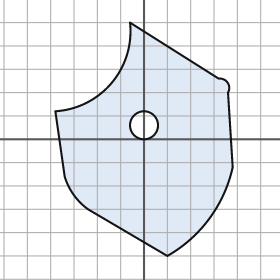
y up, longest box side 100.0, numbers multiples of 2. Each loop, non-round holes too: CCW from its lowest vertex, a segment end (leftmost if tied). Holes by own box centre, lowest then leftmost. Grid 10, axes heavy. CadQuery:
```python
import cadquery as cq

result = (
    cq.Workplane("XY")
    .moveTo(10.0, -50.0)
    .threePointArc((28.0, -34.0), (38.0, -12.0))
    .lineTo(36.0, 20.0)
    .threePointArc((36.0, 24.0), (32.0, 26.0))
    .lineTo(-6.0, 50.0)
    .threePointArc((-14.0, 24.0), (-38.0, 12.0))
    .lineTo(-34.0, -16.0)
    .threePointArc((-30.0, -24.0), (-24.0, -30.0))
    .close()
    .moveTo(0.0, 6.0)
    .circle(6.0)
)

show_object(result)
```